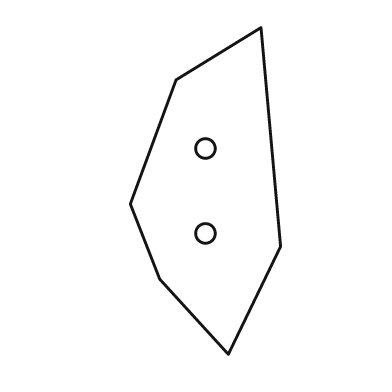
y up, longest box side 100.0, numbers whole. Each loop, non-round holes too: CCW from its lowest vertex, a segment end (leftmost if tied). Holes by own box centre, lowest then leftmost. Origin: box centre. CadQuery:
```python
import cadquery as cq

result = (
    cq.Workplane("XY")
    .moveTo(7.0, -50.0)
    .lineTo(23.0, -17.0)
    .lineTo(17.0, 50.0)
    .lineTo(-9.0, 34.0)
    .lineTo(-23.0, -4.0)
    .lineTo(-14.0, -27.0)
    .close()
    .moveTo(0.0, -13.0)
    .circle(3.0)
    .moveTo(0.0, 13.0)
    .circle(3.0)
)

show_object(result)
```